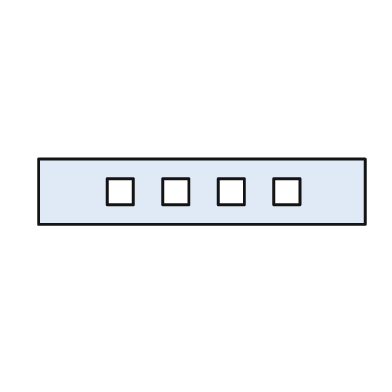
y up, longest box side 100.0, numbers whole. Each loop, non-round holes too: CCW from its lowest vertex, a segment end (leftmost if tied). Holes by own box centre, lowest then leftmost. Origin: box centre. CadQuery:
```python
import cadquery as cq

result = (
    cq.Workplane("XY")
    .moveTo(-50.0, -10.0)
    .lineTo(50.0, -10.0)
    .lineTo(50.0, 10.0)
    .lineTo(-50.0, 10.0)
    .close()
    .moveTo(-29.0, -4.0)
    .lineTo(-21.0, -4.0)
    .lineTo(-21.0, 4.0)
    .lineTo(-29.0, 4.0)
    .close()
    .moveTo(-12.0, -4.0)
    .lineTo(-4.0, -4.0)
    .lineTo(-4.0, 4.0)
    .lineTo(-12.0, 4.0)
    .close()
    .moveTo(5.0, -4.0)
    .lineTo(13.0, -4.0)
    .lineTo(13.0, 4.0)
    .lineTo(5.0, 4.0)
    .close()
    .moveTo(22.0, -4.0)
    .lineTo(30.0, -4.0)
    .lineTo(30.0, 4.0)
    .lineTo(22.0, 4.0)
    .close()
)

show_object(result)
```